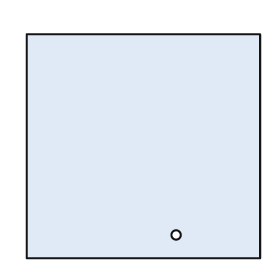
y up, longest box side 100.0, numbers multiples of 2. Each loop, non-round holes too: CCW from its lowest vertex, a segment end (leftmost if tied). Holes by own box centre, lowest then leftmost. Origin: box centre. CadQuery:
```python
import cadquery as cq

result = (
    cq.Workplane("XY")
    .moveTo(-50.0, -48.0)
    .lineTo(50.0, -48.0)
    .lineTo(50.0, 48.0)
    .lineTo(-50.0, 48.0)
    .close()
    .moveTo(14.0, -38.0)
    .circle(2.0)
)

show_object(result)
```